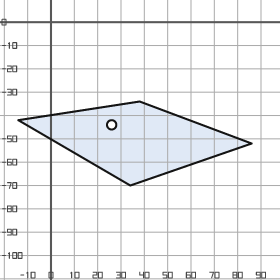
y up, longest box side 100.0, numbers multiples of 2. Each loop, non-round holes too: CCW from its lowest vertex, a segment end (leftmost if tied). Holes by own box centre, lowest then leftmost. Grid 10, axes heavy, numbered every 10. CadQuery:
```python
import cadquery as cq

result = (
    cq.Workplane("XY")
    .moveTo(34.0, -70.0)
    .lineTo(86.0, -52.0)
    .lineTo(38.0, -34.0)
    .lineTo(-14.0, -42.0)
    .close()
    .moveTo(26.0, -44.0)
    .circle(2.0)
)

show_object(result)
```